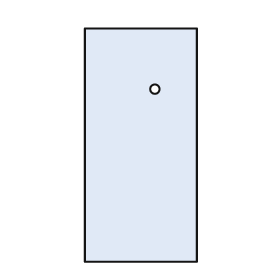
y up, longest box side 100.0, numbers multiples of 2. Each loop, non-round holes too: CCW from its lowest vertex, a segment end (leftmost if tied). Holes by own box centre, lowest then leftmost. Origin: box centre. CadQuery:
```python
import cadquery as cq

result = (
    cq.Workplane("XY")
    .moveTo(-24.0, -50.0)
    .lineTo(24.0, -50.0)
    .lineTo(24.0, 50.0)
    .lineTo(-24.0, 50.0)
    .close()
    .moveTo(6.0, 24.0)
    .circle(2.0)
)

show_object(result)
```